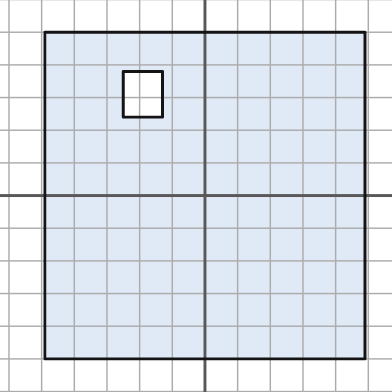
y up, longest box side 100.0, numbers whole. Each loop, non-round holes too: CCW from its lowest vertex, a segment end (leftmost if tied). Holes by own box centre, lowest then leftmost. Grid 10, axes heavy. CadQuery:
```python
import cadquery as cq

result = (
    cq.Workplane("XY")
    .moveTo(-49.0, -50.0)
    .lineTo(49.0, -50.0)
    .lineTo(49.0, 50.0)
    .lineTo(-49.0, 50.0)
    .close()
    .moveTo(-25.0, 24.0)
    .lineTo(-13.0, 24.0)
    .lineTo(-13.0, 38.0)
    .lineTo(-25.0, 38.0)
    .close()
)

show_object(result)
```